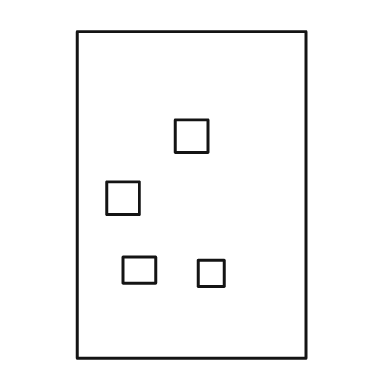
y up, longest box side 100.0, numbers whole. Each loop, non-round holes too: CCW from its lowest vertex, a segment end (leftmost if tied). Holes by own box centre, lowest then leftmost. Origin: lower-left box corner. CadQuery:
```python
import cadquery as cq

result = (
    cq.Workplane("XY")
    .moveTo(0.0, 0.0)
    .lineTo(70.0, 0.0)
    .lineTo(70.0, 100.0)
    .lineTo(0.0, 100.0)
    .close()
    .moveTo(37.0, 22.0)
    .lineTo(45.0, 22.0)
    .lineTo(45.0, 30.0)
    .lineTo(37.0, 30.0)
    .close()
    .moveTo(14.0, 23.0)
    .lineTo(24.0, 23.0)
    .lineTo(24.0, 31.0)
    .lineTo(14.0, 31.0)
    .close()
    .moveTo(9.0, 44.0)
    .lineTo(19.0, 44.0)
    .lineTo(19.0, 54.0)
    .lineTo(9.0, 54.0)
    .close()
    .moveTo(30.0, 63.0)
    .lineTo(40.0, 63.0)
    .lineTo(40.0, 73.0)
    .lineTo(30.0, 73.0)
    .close()
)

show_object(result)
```